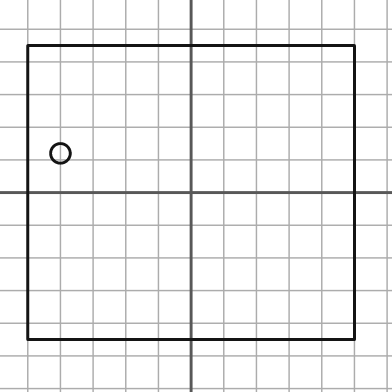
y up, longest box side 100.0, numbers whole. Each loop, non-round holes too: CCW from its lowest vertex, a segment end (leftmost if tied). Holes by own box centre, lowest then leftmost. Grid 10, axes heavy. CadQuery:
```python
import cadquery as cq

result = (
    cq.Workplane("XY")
    .moveTo(-50.0, -45.0)
    .lineTo(50.0, -45.0)
    .lineTo(50.0, 45.0)
    .lineTo(-50.0, 45.0)
    .close()
    .moveTo(-40.0, 12.0)
    .circle(3.0)
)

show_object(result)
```